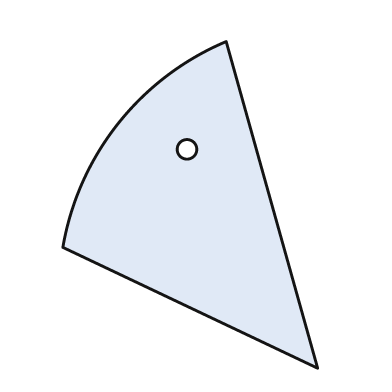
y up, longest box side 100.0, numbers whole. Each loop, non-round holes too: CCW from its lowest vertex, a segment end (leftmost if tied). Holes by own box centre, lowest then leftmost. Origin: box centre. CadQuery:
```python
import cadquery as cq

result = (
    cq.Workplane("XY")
    .moveTo(39.0, -50.0)
    .lineTo(11.0, 50.0)
    .threePointArc((-22.0, 25.0), (-39.0, -13.0))
    .close()
    .moveTo(-1.0, 17.0)
    .circle(3.0)
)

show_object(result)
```